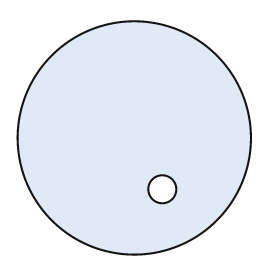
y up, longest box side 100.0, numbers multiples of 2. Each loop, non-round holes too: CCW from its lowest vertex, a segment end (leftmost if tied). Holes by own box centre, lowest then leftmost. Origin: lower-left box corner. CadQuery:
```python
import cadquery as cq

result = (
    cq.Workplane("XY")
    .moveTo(50.0, 50.0)
    .circle(50.0)
    .moveTo(62.0, 28.0)
    .circle(6.0)
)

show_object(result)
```